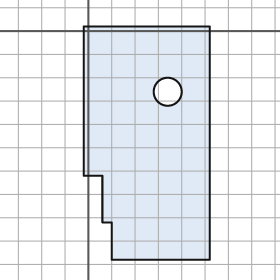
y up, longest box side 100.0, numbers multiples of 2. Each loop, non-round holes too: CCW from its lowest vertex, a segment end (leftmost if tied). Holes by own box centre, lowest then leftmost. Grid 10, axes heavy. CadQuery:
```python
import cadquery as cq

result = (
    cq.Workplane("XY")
    .moveTo(10.0, -98.0)
    .lineTo(52.0, -98.0)
    .lineTo(52.0, 2.0)
    .lineTo(-2.0, 2.0)
    .lineTo(-2.0, -62.0)
    .lineTo(6.0, -62.0)
    .lineTo(6.0, -82.0)
    .lineTo(10.0, -82.0)
    .close()
    .moveTo(34.0, -26.0)
    .circle(6.0)
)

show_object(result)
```